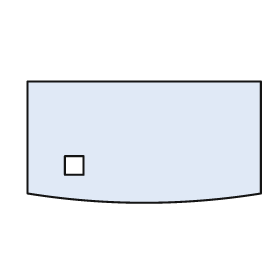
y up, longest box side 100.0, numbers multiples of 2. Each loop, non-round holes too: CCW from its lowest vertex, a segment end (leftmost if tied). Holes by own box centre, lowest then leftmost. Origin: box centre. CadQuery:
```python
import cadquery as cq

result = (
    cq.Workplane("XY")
    .moveTo(-50.0, -22.0)
    .threePointArc((0.0, -26.0), (50.0, -22.0))
    .lineTo(50.0, 26.0)
    .lineTo(-50.0, 26.0)
    .close()
    .moveTo(-34.0, -14.0)
    .lineTo(-26.0, -14.0)
    .lineTo(-26.0, -6.0)
    .lineTo(-34.0, -6.0)
    .close()
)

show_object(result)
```